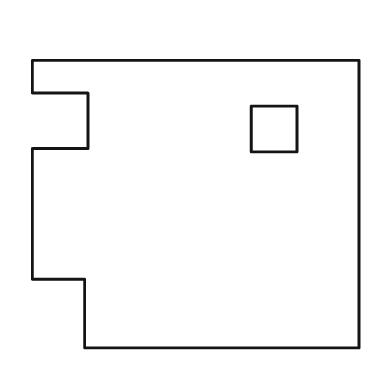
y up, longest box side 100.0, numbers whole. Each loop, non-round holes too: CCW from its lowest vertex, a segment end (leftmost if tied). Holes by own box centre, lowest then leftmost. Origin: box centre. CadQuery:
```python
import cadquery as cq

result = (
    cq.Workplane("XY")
    .moveTo(-34.0, -44.0)
    .lineTo(50.0, -44.0)
    .lineTo(50.0, 44.0)
    .lineTo(-50.0, 44.0)
    .lineTo(-50.0, 34.0)
    .lineTo(-33.0, 34.0)
    .lineTo(-33.0, 17.0)
    .lineTo(-50.0, 17.0)
    .lineTo(-50.0, -23.0)
    .lineTo(-34.0, -23.0)
    .close()
    .moveTo(17.0, 16.0)
    .lineTo(31.0, 16.0)
    .lineTo(31.0, 30.0)
    .lineTo(17.0, 30.0)
    .close()
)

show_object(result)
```